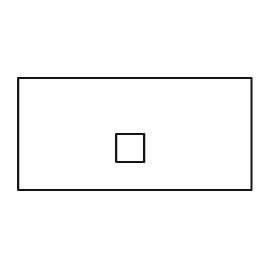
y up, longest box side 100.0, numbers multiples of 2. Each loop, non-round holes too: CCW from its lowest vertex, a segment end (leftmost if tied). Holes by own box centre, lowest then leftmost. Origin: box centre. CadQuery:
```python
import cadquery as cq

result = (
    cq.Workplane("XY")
    .moveTo(-50.0, -24.0)
    .lineTo(50.0, -24.0)
    .lineTo(50.0, 24.0)
    .lineTo(-50.0, 24.0)
    .close()
    .moveTo(-8.0, -12.0)
    .lineTo(4.0, -12.0)
    .lineTo(4.0, 0.0)
    .lineTo(-8.0, 0.0)
    .close()
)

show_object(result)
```